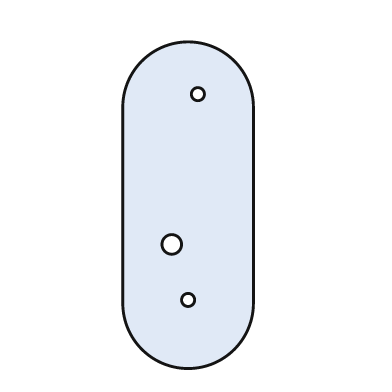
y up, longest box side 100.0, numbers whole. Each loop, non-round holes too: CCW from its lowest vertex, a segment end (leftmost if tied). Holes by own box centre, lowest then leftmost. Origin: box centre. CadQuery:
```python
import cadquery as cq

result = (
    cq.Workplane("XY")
    .moveTo(-20.0, -30.0)
    .threePointArc((0.0, -50.0), (20.0, -30.0))
    .lineTo(20.0, 30.0)
    .threePointArc((0.0, 50.0), (-20.0, 30.0))
    .close()
    .moveTo(0.0, -29.0)
    .circle(2.0)
    .moveTo(-5.0, -12.0)
    .circle(3.0)
    .moveTo(3.0, 34.0)
    .circle(2.0)
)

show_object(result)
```